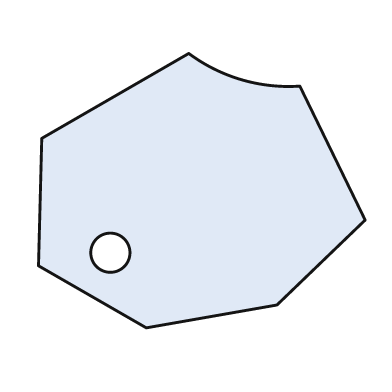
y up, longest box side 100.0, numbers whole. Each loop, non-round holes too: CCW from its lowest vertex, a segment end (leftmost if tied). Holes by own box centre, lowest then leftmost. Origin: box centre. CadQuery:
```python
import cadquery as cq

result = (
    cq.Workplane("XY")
    .moveTo(-17.0, -42.0)
    .lineTo(23.0, -35.0)
    .lineTo(50.0, -9.0)
    .lineTo(30.0, 32.0)
    .threePointArc((12.0, 34.0), (-4.0, 42.0))
    .lineTo(-49.0, 16.0)
    .lineTo(-50.0, -23.0)
    .close()
    .moveTo(-28.0, -19.0)
    .circle(6.0)
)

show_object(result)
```